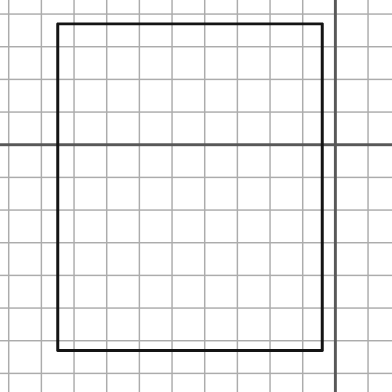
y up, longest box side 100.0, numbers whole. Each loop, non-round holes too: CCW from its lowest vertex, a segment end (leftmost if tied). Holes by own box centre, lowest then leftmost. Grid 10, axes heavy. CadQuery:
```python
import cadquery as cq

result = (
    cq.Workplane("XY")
    .moveTo(-85.0, -63.0)
    .lineTo(-4.0, -63.0)
    .lineTo(-4.0, 37.0)
    .lineTo(-85.0, 37.0)
    .close()
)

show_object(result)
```